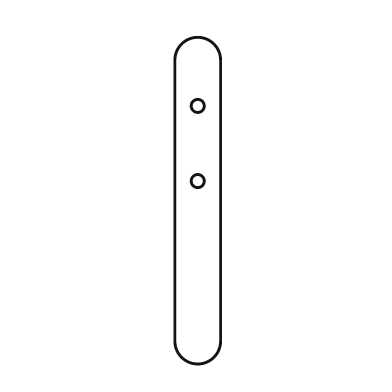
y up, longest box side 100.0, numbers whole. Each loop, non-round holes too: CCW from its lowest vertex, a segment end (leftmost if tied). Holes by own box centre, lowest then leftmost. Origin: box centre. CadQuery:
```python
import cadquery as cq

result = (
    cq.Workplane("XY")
    .moveTo(-7.0, -43.0)
    .threePointArc((0.0, -50.0), (7.0, -43.0))
    .lineTo(7.0, 43.0)
    .threePointArc((0.0, 50.0), (-7.0, 43.0))
    .close()
    .moveTo(0.0, 6.0)
    .circle(2.0)
    .moveTo(0.0, 29.0)
    .circle(2.0)
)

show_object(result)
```